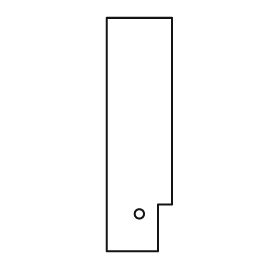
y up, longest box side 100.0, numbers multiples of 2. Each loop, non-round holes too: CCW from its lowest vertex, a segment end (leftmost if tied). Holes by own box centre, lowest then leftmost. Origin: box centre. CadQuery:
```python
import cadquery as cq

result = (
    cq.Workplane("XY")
    .moveTo(-14.0, -50.0)
    .lineTo(8.0, -50.0)
    .lineTo(8.0, -30.0)
    .lineTo(14.0, -30.0)
    .lineTo(14.0, 50.0)
    .lineTo(-14.0, 50.0)
    .close()
    .moveTo(0.0, -34.0)
    .circle(2.0)
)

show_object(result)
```